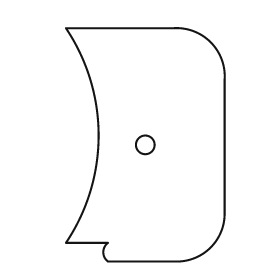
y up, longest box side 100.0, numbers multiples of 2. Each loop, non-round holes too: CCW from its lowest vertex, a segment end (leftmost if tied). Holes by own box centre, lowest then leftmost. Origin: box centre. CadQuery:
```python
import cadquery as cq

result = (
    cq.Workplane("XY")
    .moveTo(-16.0, -50.0)
    .lineTo(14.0, -50.0)
    .threePointArc((28.0, -44.0), (34.0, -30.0))
    .lineTo(34.0, 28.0)
    .threePointArc((28.0, 44.0), (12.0, 50.0))
    .lineTo(-34.0, 50.0)
    .threePointArc((-20.0, 4.0), (-34.0, -42.0))
    .lineTo(-16.0, -42.0)
    .threePointArc((-18.0, -46.0), (-16.0, -50.0))
    .close()
    .moveTo(0.0, 0.0)
    .circle(4.0)
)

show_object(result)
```